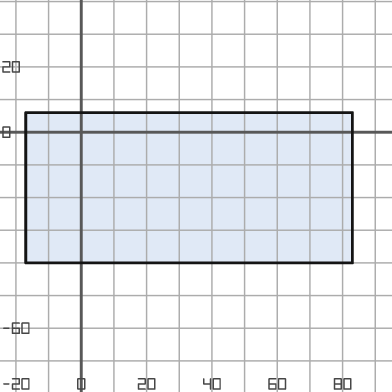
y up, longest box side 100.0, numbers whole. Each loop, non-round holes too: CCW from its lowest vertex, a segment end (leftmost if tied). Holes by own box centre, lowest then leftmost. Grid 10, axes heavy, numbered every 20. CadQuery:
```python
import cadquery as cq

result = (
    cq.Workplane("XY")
    .moveTo(-17.0, -40.0)
    .lineTo(83.0, -40.0)
    .lineTo(83.0, 6.0)
    .lineTo(-17.0, 6.0)
    .close()
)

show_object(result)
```